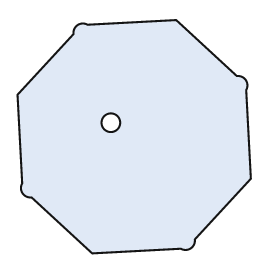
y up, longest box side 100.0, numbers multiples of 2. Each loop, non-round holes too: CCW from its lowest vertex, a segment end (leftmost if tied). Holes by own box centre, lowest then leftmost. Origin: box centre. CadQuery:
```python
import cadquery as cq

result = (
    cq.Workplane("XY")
    .moveTo(-18.0, -50.0)
    .lineTo(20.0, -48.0)
    .threePointArc((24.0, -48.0), (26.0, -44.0))
    .lineTo(50.0, -18.0)
    .lineTo(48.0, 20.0)
    .threePointArc((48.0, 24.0), (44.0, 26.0))
    .lineTo(18.0, 50.0)
    .lineTo(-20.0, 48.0)
    .threePointArc((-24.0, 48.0), (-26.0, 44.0))
    .lineTo(-50.0, 18.0)
    .lineTo(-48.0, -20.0)
    .threePointArc((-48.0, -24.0), (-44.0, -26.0))
    .close()
    .moveTo(-10.0, 6.0)
    .circle(4.0)
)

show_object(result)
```